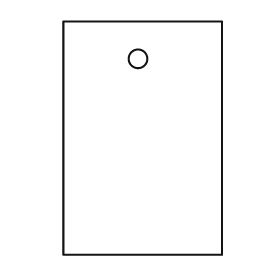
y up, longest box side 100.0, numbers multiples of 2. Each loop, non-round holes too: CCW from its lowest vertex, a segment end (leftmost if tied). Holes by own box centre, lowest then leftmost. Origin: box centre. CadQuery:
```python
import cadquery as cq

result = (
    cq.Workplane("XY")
    .moveTo(-34.0, -50.0)
    .lineTo(34.0, -50.0)
    .lineTo(34.0, 50.0)
    .lineTo(-34.0, 50.0)
    .close()
    .moveTo(-2.0, 34.0)
    .circle(4.0)
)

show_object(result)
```